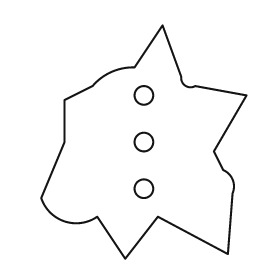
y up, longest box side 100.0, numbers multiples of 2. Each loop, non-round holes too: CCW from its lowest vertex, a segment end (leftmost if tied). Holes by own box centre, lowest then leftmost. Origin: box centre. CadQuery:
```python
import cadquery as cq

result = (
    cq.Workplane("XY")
    .moveTo(-8.0, -50.0)
    .lineTo(6.0, -32.0)
    .lineTo(36.0, -48.0)
    .lineTo(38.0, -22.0)
    .threePointArc((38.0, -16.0), (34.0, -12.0))
    .lineTo(30.0, -4.0)
    .lineTo(44.0, 20.0)
    .lineTo(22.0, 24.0)
    .threePointArc((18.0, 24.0), (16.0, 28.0))
    .lineTo(8.0, 50.0)
    .lineTo(-4.0, 32.0)
    .threePointArc((-14.0, 30.0), (-22.0, 24.0))
    .lineTo(-34.0, 18.0)
    .lineTo(-34.0, 0.0)
    .lineTo(-44.0, -24.0)
    .threePointArc((-34.0, -34.0), (-20.0, -32.0))
    .close()
    .moveTo(0.0, -20.0)
    .circle(4.0)
    .moveTo(0.0, 0.0)
    .circle(4.0)
    .moveTo(0.0, 20.0)
    .circle(4.0)
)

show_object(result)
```